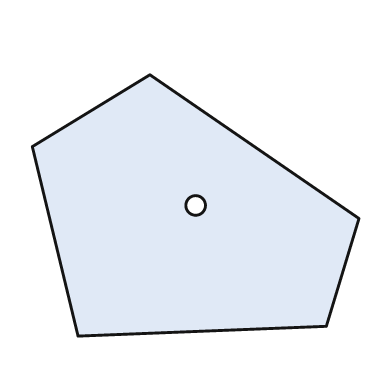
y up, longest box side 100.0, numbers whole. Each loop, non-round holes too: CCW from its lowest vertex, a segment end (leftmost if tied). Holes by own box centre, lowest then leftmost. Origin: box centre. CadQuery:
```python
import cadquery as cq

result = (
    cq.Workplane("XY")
    .moveTo(-36.0, -40.0)
    .lineTo(40.0, -37.0)
    .lineTo(50.0, -4.0)
    .lineTo(-14.0, 40.0)
    .lineTo(-50.0, 18.0)
    .close()
    .moveTo(0.0, 0.0)
    .circle(3.0)
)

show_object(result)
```